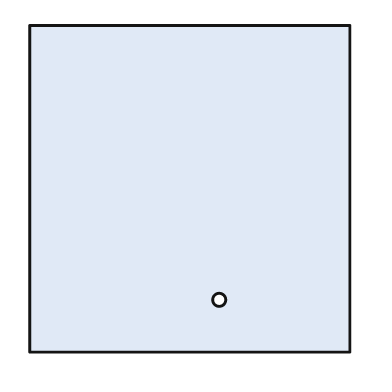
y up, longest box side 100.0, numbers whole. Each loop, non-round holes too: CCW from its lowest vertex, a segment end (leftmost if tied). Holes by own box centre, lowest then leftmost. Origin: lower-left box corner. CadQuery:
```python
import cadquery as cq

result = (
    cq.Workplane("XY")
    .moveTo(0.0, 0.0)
    .lineTo(98.0, 0.0)
    .lineTo(98.0, 100.0)
    .lineTo(0.0, 100.0)
    .close()
    .moveTo(58.0, 16.0)
    .circle(2.0)
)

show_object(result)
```